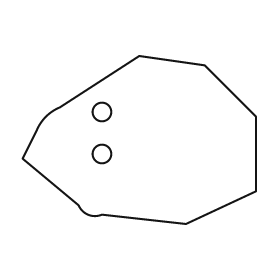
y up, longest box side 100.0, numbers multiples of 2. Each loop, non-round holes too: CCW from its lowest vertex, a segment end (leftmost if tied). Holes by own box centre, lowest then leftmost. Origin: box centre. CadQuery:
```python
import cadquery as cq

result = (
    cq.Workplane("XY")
    .moveTo(20.0, -36.0)
    .lineTo(50.0, -22.0)
    .lineTo(50.0, 10.0)
    .lineTo(28.0, 32.0)
    .lineTo(0.0, 36.0)
    .lineTo(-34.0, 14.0)
    .threePointArc((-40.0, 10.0), (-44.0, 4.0))
    .lineTo(-50.0, -8.0)
    .lineTo(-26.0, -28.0)
    .threePointArc((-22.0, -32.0), (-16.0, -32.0))
    .close()
    .moveTo(-16.0, -6.0)
    .circle(4.0)
    .moveTo(-16.0, 12.0)
    .circle(4.0)
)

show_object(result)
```